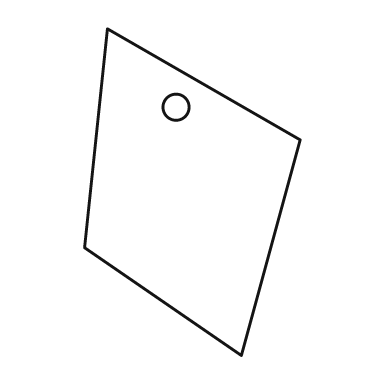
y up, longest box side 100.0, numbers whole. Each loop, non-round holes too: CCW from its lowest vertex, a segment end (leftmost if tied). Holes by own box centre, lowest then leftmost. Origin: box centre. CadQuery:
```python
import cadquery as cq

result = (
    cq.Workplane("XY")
    .moveTo(15.0, -50.0)
    .lineTo(33.0, 16.0)
    .lineTo(-26.0, 50.0)
    .lineTo(-33.0, -17.0)
    .close()
    .moveTo(-5.0, 26.0)
    .circle(4.0)
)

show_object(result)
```